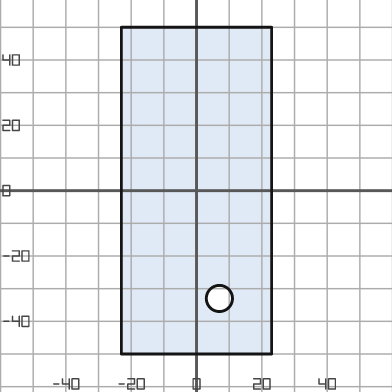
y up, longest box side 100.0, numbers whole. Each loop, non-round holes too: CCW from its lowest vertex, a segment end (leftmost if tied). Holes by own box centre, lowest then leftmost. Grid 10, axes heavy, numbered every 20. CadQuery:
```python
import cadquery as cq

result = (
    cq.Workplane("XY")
    .moveTo(-23.0, -50.0)
    .lineTo(23.0, -50.0)
    .lineTo(23.0, 50.0)
    .lineTo(-23.0, 50.0)
    .close()
    .moveTo(7.0, -33.0)
    .circle(4.0)
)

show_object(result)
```